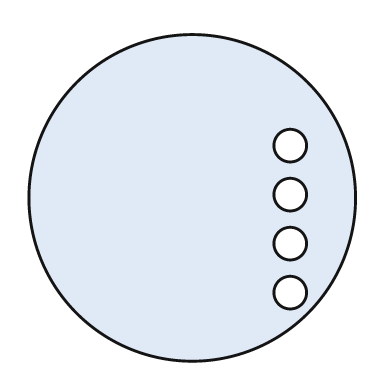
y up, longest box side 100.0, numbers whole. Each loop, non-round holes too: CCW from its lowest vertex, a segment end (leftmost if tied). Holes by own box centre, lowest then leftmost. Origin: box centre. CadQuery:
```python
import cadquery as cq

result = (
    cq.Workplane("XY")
    .moveTo(0.0, 0.0)
    .circle(50.0)
    .moveTo(30.0, -29.0)
    .circle(5.0)
    .moveTo(30.0, -14.0)
    .circle(5.0)
    .moveTo(30.0, 1.0)
    .circle(5.0)
    .moveTo(30.0, 16.0)
    .circle(5.0)
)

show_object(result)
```